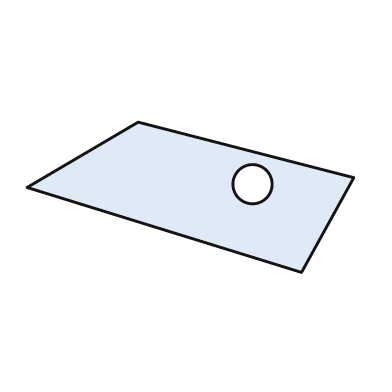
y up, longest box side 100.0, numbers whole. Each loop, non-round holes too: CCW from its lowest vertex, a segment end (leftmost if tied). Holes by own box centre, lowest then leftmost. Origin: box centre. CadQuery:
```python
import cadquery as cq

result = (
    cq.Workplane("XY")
    .moveTo(34.0, -23.0)
    .lineTo(50.0, 6.0)
    .lineTo(-16.0, 23.0)
    .lineTo(-50.0, 3.0)
    .close()
    .moveTo(19.0, 4.0)
    .circle(6.0)
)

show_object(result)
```